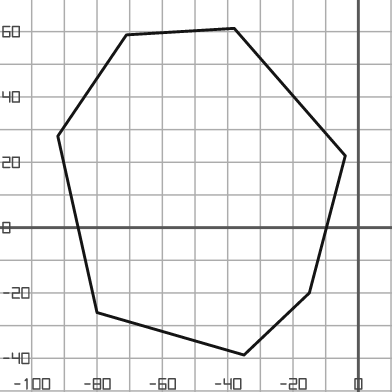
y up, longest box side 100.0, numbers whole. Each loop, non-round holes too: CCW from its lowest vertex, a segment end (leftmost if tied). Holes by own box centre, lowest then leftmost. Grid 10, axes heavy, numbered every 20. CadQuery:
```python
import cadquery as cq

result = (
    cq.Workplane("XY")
    .moveTo(-35.0, -39.0)
    .lineTo(-15.0, -20.0)
    .lineTo(-4.0, 22.0)
    .lineTo(-38.0, 61.0)
    .lineTo(-71.0, 59.0)
    .lineTo(-92.0, 28.0)
    .lineTo(-80.0, -26.0)
    .close()
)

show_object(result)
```